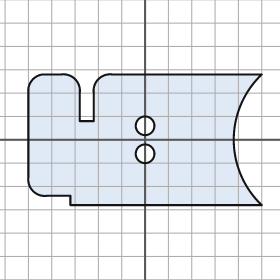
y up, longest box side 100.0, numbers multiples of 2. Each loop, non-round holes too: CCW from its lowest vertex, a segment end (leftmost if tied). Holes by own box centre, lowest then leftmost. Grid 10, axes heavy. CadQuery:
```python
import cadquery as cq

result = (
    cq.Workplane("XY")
    .moveTo(-32.0, -28.0)
    .lineTo(50.0, -28.0)
    .threePointArc((38.0, 0.0), (50.0, 28.0))
    .lineTo(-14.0, 28.0)
    .threePointArc((-20.0, 26.0), (-22.0, 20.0))
    .lineTo(-22.0, 8.0)
    .lineTo(-28.0, 8.0)
    .lineTo(-28.0, 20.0)
    .threePointArc((-30.0, 26.0), (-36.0, 28.0))
    .lineTo(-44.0, 28.0)
    .threePointArc((-48.0, 26.0), (-50.0, 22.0))
    .lineTo(-50.0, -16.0)
    .threePointArc((-48.0, -22.0), (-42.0, -24.0))
    .lineTo(-32.0, -24.0)
    .close()
    .moveTo(0.0, -6.0)
    .circle(4.0)
    .moveTo(0.0, 6.0)
    .circle(4.0)
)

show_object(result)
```